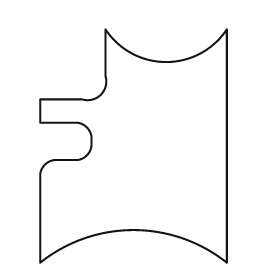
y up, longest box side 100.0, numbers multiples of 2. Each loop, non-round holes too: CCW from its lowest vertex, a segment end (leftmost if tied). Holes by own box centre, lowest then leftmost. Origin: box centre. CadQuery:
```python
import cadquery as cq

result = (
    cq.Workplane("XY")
    .moveTo(-40.0, -50.0)
    .threePointArc((0.0, -36.0), (40.0, -50.0))
    .lineTo(40.0, 50.0)
    .threePointArc((14.0, 36.0), (-12.0, 50.0))
    .lineTo(-12.0, 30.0)
    .threePointArc((-14.0, 22.0), (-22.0, 20.0))
    .lineTo(-40.0, 20.0)
    .lineTo(-40.0, 10.0)
    .lineTo(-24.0, 10.0)
    .threePointArc((-20.0, 8.0), (-18.0, 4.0))
    .lineTo(-18.0, 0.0)
    .threePointArc((-20.0, -4.0), (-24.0, -6.0))
    .lineTo(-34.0, -6.0)
    .threePointArc((-38.0, -8.0), (-40.0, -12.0))
    .close()
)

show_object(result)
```